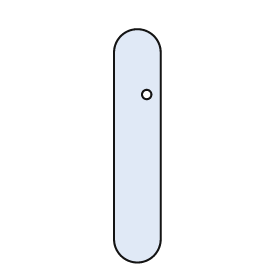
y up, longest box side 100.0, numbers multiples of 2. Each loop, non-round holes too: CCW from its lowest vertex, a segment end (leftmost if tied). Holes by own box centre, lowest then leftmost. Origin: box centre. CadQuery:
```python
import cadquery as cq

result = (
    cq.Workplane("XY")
    .moveTo(-10.0, -40.0)
    .threePointArc((0.0, -50.0), (10.0, -40.0))
    .lineTo(10.0, 40.0)
    .threePointArc((0.0, 50.0), (-10.0, 40.0))
    .close()
    .moveTo(4.0, 22.0)
    .circle(2.0)
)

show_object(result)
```